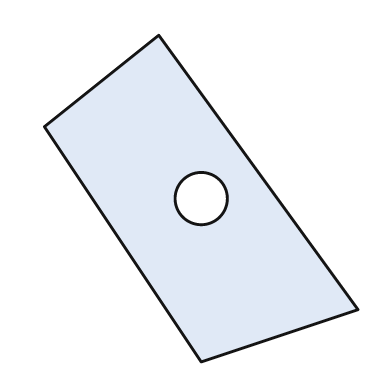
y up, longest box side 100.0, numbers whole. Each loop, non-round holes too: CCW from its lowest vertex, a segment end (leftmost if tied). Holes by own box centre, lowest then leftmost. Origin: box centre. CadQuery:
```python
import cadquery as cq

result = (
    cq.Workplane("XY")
    .moveTo(0.0, -50.0)
    .lineTo(48.0, -34.0)
    .lineTo(-13.0, 50.0)
    .lineTo(-48.0, 22.0)
    .close()
    .moveTo(0.0, 0.0)
    .circle(8.0)
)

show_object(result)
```